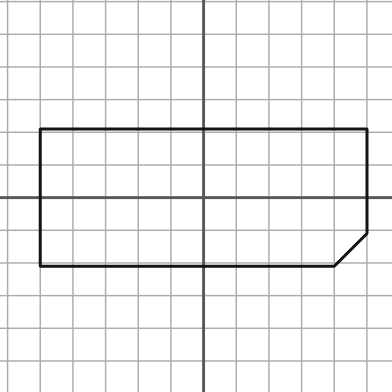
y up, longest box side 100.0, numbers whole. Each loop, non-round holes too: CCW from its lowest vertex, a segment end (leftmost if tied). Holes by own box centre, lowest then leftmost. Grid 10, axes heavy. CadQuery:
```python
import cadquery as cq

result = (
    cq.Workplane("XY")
    .moveTo(-50.0, -21.0)
    .lineTo(40.0, -21.0)
    .lineTo(50.0, -11.0)
    .lineTo(50.0, 21.0)
    .lineTo(-50.0, 21.0)
    .close()
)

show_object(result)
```